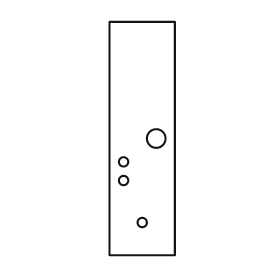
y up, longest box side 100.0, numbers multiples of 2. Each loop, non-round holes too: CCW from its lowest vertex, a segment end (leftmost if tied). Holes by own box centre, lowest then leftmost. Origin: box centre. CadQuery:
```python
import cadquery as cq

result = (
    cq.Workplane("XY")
    .moveTo(-14.0, -50.0)
    .lineTo(14.0, -50.0)
    .lineTo(14.0, 50.0)
    .lineTo(-14.0, 50.0)
    .close()
    .moveTo(0.0, -36.0)
    .circle(2.0)
    .moveTo(-8.0, -18.0)
    .circle(2.0)
    .moveTo(-8.0, -10.0)
    .circle(2.0)
    .moveTo(6.0, 0.0)
    .circle(4.0)
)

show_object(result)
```